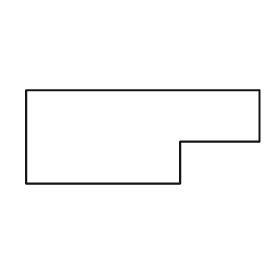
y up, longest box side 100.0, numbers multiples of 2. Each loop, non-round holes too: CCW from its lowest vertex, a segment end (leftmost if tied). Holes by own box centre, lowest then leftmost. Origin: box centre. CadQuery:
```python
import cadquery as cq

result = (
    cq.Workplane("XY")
    .moveTo(-50.0, -20.0)
    .lineTo(16.0, -20.0)
    .lineTo(16.0, -2.0)
    .lineTo(50.0, -2.0)
    .lineTo(50.0, 20.0)
    .lineTo(-50.0, 20.0)
    .close()
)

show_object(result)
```